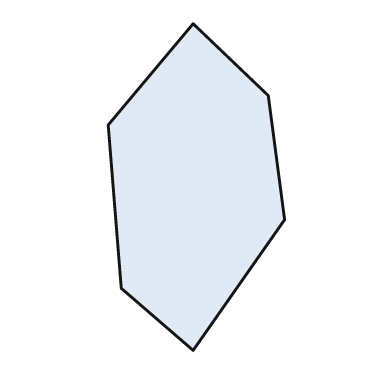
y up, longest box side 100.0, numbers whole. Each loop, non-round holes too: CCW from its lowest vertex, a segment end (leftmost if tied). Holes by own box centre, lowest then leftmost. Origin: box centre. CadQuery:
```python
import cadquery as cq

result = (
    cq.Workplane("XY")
    .moveTo(-1.0, -50.0)
    .lineTo(27.0, -10.0)
    .lineTo(22.0, 28.0)
    .lineTo(-1.0, 50.0)
    .lineTo(-27.0, 19.0)
    .lineTo(-23.0, -31.0)
    .close()
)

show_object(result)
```